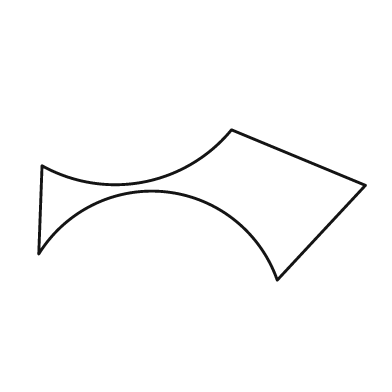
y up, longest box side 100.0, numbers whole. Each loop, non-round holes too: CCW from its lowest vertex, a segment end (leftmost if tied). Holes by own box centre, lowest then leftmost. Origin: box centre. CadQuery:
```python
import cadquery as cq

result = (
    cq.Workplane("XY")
    .moveTo(23.0, -23.0)
    .lineTo(50.0, 6.0)
    .lineTo(9.0, 23.0)
    .threePointArc((-18.0, 7.0), (-49.0, 12.0))
    .lineTo(-50.0, -15.0)
    .threePointArc((-11.0, 4.0), (23.0, -23.0))
    .close()
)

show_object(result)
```